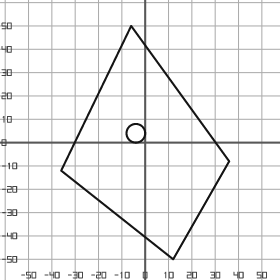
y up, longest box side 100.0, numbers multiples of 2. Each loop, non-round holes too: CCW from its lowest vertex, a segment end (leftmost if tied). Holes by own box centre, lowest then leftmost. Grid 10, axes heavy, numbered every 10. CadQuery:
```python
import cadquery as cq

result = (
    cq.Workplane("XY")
    .moveTo(12.0, -50.0)
    .lineTo(36.0, -8.0)
    .lineTo(-6.0, 50.0)
    .lineTo(-36.0, -12.0)
    .close()
    .moveTo(-4.0, 4.0)
    .circle(4.0)
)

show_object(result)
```